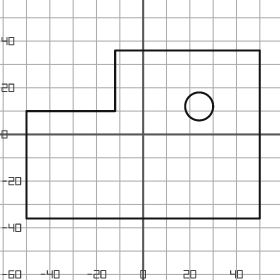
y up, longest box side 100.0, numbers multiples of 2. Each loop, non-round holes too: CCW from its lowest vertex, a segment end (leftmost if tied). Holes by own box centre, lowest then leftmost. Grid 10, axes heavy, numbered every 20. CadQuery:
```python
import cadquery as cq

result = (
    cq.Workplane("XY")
    .moveTo(-50.0, -36.0)
    .lineTo(50.0, -36.0)
    .lineTo(50.0, 36.0)
    .lineTo(-12.0, 36.0)
    .lineTo(-12.0, 10.0)
    .lineTo(-50.0, 10.0)
    .close()
    .moveTo(24.0, 12.0)
    .circle(6.0)
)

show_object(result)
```